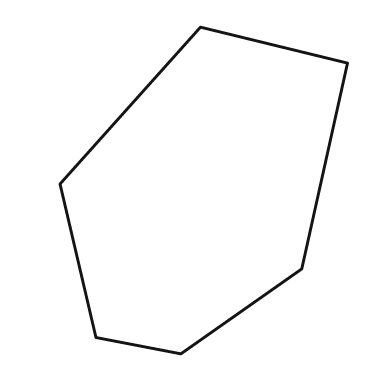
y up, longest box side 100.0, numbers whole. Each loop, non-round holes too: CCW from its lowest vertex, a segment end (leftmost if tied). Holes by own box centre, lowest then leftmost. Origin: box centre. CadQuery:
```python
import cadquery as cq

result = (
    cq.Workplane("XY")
    .moveTo(-7.0, -50.0)
    .lineTo(30.0, -24.0)
    .lineTo(44.0, 39.0)
    .lineTo(-1.0, 50.0)
    .lineTo(-44.0, 2.0)
    .lineTo(-33.0, -45.0)
    .close()
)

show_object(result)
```